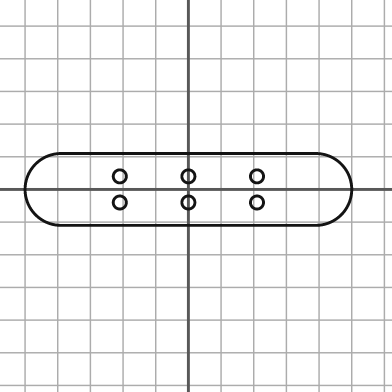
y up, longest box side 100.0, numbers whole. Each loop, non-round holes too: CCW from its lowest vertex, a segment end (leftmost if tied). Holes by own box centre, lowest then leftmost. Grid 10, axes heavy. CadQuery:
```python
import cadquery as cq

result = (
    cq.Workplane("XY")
    .moveTo(-39.0, -11.0)
    .lineTo(39.0, -11.0)
    .threePointArc((50.0, 0.0), (39.0, 11.0))
    .lineTo(-39.0, 11.0)
    .threePointArc((-50.0, 0.0), (-39.0, -11.0))
    .close()
    .moveTo(-21.0, -4.0)
    .circle(2.0)
    .moveTo(0.0, -4.0)
    .circle(2.0)
    .moveTo(21.0, -4.0)
    .circle(2.0)
    .moveTo(-21.0, 4.0)
    .circle(2.0)
    .moveTo(0.0, 4.0)
    .circle(2.0)
    .moveTo(21.0, 4.0)
    .circle(2.0)
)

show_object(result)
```